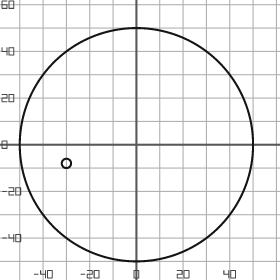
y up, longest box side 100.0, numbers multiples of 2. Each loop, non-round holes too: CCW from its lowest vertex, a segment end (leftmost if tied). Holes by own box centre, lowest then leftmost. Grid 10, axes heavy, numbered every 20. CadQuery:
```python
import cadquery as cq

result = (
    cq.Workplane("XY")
    .moveTo(0.0, 0.0)
    .circle(50.0)
    .moveTo(-30.0, -8.0)
    .circle(2.0)
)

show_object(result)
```